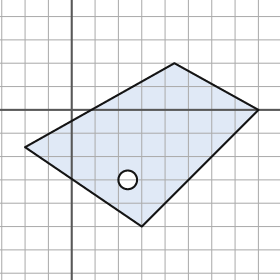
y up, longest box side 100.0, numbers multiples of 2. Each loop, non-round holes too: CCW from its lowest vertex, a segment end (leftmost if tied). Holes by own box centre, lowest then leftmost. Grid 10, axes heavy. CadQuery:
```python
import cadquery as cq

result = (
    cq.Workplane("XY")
    .moveTo(30.0, -50.0)
    .lineTo(80.0, 0.0)
    .lineTo(44.0, 20.0)
    .lineTo(-20.0, -16.0)
    .close()
    .moveTo(24.0, -30.0)
    .circle(4.0)
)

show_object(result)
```